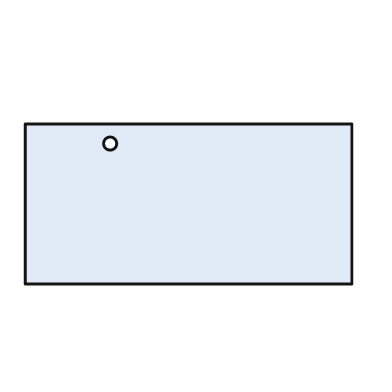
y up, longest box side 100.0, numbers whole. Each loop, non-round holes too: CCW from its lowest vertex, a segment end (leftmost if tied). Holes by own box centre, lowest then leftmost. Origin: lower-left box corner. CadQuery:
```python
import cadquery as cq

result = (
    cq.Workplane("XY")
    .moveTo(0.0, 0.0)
    .lineTo(100.0, 0.0)
    .lineTo(100.0, 49.0)
    .lineTo(0.0, 49.0)
    .close()
    .moveTo(26.0, 43.0)
    .circle(2.0)
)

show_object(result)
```